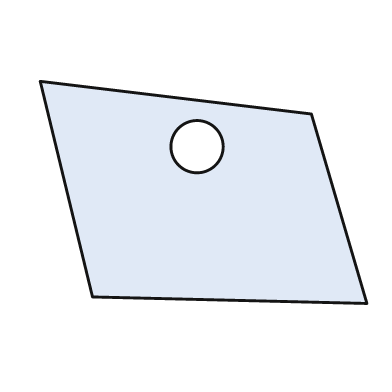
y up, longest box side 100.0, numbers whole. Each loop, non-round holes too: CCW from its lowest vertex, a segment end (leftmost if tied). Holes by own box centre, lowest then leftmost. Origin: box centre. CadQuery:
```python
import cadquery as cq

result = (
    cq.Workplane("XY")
    .moveTo(50.0, -34.0)
    .lineTo(33.0, 24.0)
    .lineTo(-50.0, 34.0)
    .lineTo(-34.0, -32.0)
    .close()
    .moveTo(-2.0, 14.0)
    .circle(8.0)
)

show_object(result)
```